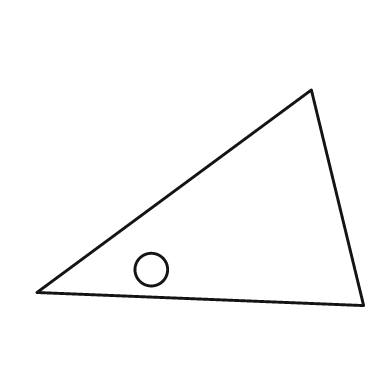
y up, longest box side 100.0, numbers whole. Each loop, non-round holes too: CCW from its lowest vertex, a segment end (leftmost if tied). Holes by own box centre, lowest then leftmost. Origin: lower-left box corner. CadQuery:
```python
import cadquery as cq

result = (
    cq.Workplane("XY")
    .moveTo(100.0, 0.0)
    .lineTo(84.0, 66.0)
    .lineTo(0.0, 4.0)
    .close()
    .moveTo(35.0, 11.0)
    .circle(5.0)
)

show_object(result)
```